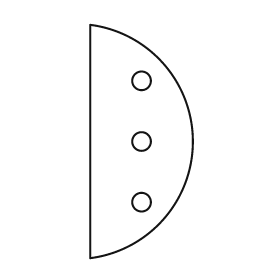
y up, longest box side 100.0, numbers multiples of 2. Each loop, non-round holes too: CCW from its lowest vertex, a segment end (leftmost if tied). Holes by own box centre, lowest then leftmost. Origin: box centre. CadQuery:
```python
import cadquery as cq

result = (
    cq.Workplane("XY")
    .moveTo(-22.0, -50.0)
    .threePointArc((22.0, 0.0), (-22.0, 50.0))
    .close()
    .moveTo(0.0, -26.0)
    .circle(4.0)
    .moveTo(0.0, 0.0)
    .circle(4.0)
    .moveTo(0.0, 26.0)
    .circle(4.0)
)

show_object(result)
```